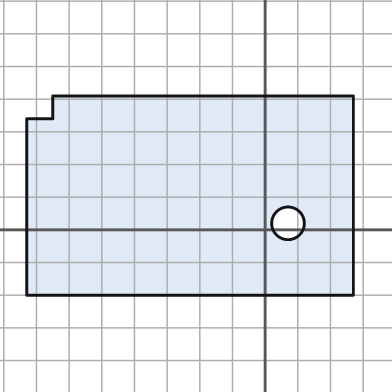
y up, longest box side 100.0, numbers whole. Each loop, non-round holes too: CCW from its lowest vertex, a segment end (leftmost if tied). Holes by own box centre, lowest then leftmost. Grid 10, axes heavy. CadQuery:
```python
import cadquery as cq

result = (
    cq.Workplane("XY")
    .moveTo(-73.0, -20.0)
    .lineTo(27.0, -20.0)
    .lineTo(27.0, 41.0)
    .lineTo(-65.0, 41.0)
    .lineTo(-65.0, 34.0)
    .lineTo(-73.0, 34.0)
    .close()
    .moveTo(7.0, 2.0)
    .circle(5.0)
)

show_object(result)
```